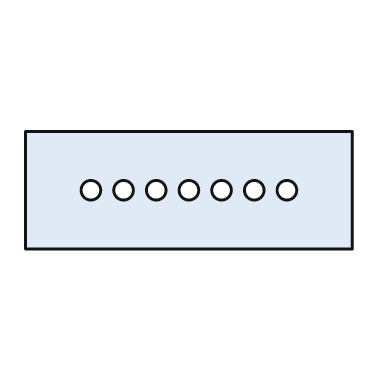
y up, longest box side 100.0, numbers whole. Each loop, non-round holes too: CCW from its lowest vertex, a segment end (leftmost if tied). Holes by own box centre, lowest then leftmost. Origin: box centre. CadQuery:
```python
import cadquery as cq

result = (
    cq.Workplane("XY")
    .moveTo(-50.0, -18.0)
    .lineTo(50.0, -18.0)
    .lineTo(50.0, 18.0)
    .lineTo(-50.0, 18.0)
    .close()
    .moveTo(-30.0, 0.0)
    .circle(3.0)
    .moveTo(-20.0, 0.0)
    .circle(3.0)
    .moveTo(-10.0, 0.0)
    .circle(3.0)
    .moveTo(0.0, 0.0)
    .circle(3.0)
    .moveTo(10.0, 0.0)
    .circle(3.0)
    .moveTo(20.0, 0.0)
    .circle(3.0)
    .moveTo(30.0, 0.0)
    .circle(3.0)
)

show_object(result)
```